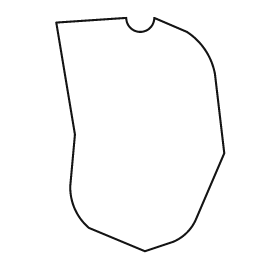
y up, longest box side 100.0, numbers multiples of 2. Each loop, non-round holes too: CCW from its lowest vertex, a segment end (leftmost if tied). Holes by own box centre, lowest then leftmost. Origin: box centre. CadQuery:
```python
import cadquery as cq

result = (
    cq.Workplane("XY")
    .moveTo(2.0, -50.0)
    .lineTo(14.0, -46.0)
    .threePointArc((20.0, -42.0), (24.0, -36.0))
    .lineTo(36.0, -8.0)
    .lineTo(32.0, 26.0)
    .threePointArc((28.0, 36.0), (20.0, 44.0))
    .lineTo(6.0, 50.0)
    .threePointArc((0.0, 44.0), (-6.0, 50.0))
    .lineTo(-36.0, 48.0)
    .lineTo(-28.0, 0.0)
    .lineTo(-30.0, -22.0)
    .threePointArc((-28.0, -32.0), (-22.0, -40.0))
    .close()
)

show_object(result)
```